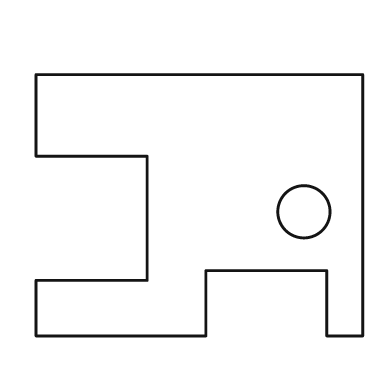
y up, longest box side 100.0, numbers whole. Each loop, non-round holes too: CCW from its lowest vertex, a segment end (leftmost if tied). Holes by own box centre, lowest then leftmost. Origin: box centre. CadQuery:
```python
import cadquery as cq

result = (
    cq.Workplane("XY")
    .moveTo(-50.0, -40.0)
    .lineTo(2.0, -40.0)
    .lineTo(2.0, -20.0)
    .lineTo(39.0, -20.0)
    .lineTo(39.0, -40.0)
    .lineTo(50.0, -40.0)
    .lineTo(50.0, 40.0)
    .lineTo(-50.0, 40.0)
    .lineTo(-50.0, 15.0)
    .lineTo(-16.0, 15.0)
    .lineTo(-16.0, -23.0)
    .lineTo(-50.0, -23.0)
    .close()
    .moveTo(32.0, -2.0)
    .circle(8.0)
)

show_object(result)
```